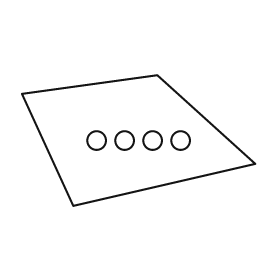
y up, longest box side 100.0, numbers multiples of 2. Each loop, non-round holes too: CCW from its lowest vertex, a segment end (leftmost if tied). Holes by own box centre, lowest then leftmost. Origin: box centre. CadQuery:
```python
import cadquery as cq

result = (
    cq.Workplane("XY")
    .moveTo(-28.0, -28.0)
    .lineTo(50.0, -10.0)
    .lineTo(8.0, 28.0)
    .lineTo(-50.0, 20.0)
    .close()
    .moveTo(-18.0, 0.0)
    .circle(4.0)
    .moveTo(-6.0, 0.0)
    .circle(4.0)
    .moveTo(6.0, 0.0)
    .circle(4.0)
    .moveTo(18.0, 0.0)
    .circle(4.0)
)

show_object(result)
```